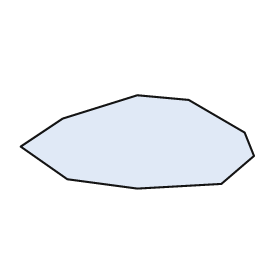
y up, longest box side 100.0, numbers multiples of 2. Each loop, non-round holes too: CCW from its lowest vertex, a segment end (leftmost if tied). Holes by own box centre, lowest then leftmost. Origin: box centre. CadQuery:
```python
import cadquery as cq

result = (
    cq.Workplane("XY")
    .moveTo(0.0, -20.0)
    .lineTo(36.0, -18.0)
    .lineTo(50.0, -6.0)
    .lineTo(46.0, 4.0)
    .lineTo(22.0, 18.0)
    .lineTo(0.0, 20.0)
    .lineTo(-32.0, 10.0)
    .lineTo(-50.0, -2.0)
    .lineTo(-30.0, -16.0)
    .close()
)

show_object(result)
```